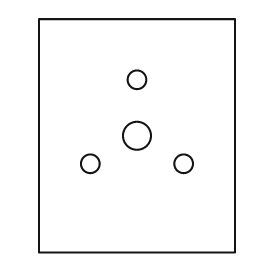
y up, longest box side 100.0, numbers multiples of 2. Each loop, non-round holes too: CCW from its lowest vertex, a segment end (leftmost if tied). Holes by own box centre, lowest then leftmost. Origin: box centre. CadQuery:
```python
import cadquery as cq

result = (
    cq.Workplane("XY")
    .moveTo(-42.0, -50.0)
    .lineTo(42.0, -50.0)
    .lineTo(42.0, 50.0)
    .lineTo(-42.0, 50.0)
    .close()
    .moveTo(-20.0, -12.0)
    .circle(4.0)
    .moveTo(20.0, -12.0)
    .circle(4.0)
    .moveTo(0.0, 0.0)
    .circle(6.0)
    .moveTo(0.0, 24.0)
    .circle(4.0)
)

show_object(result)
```